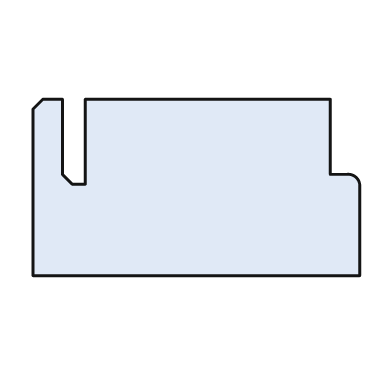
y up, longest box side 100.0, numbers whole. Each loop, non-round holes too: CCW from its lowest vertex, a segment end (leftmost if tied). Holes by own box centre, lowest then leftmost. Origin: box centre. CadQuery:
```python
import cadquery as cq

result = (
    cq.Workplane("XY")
    .moveTo(-50.0, -27.0)
    .lineTo(50.0, -27.0)
    .lineTo(50.0, 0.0)
    .threePointArc((49.0, 3.0), (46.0, 4.0))
    .lineTo(41.0, 4.0)
    .lineTo(41.0, 27.0)
    .lineTo(-34.0, 27.0)
    .lineTo(-34.0, 1.0)
    .lineTo(-38.0, 1.0)
    .lineTo(-41.0, 4.0)
    .lineTo(-41.0, 27.0)
    .lineTo(-47.0, 27.0)
    .lineTo(-50.0, 24.0)
    .close()
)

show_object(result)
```